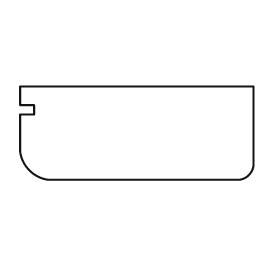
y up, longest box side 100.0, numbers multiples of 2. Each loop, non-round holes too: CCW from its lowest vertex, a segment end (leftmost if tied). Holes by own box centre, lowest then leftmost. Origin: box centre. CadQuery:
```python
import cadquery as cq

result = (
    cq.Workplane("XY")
    .moveTo(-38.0, -20.0)
    .lineTo(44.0, -20.0)
    .threePointArc((48.0, -18.0), (50.0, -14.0))
    .lineTo(50.0, 20.0)
    .lineTo(-50.0, 20.0)
    .lineTo(-50.0, 12.0)
    .lineTo(-44.0, 12.0)
    .lineTo(-44.0, 8.0)
    .lineTo(-50.0, 8.0)
    .lineTo(-50.0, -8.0)
    .threePointArc((-46.0, -16.0), (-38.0, -20.0))
    .close()
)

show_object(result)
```